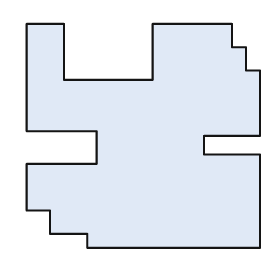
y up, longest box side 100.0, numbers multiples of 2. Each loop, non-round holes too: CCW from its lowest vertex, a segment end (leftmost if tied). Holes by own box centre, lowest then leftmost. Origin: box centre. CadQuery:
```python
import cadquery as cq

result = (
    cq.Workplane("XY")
    .moveTo(-24.0, -48.0)
    .lineTo(50.0, -48.0)
    .lineTo(50.0, -8.0)
    .lineTo(26.0, -8.0)
    .lineTo(26.0, 0.0)
    .lineTo(50.0, 0.0)
    .lineTo(50.0, 28.0)
    .lineTo(44.0, 28.0)
    .lineTo(44.0, 38.0)
    .lineTo(38.0, 38.0)
    .lineTo(38.0, 48.0)
    .lineTo(4.0, 48.0)
    .lineTo(4.0, 24.0)
    .lineTo(-34.0, 24.0)
    .lineTo(-34.0, 48.0)
    .lineTo(-50.0, 48.0)
    .lineTo(-50.0, 2.0)
    .lineTo(-20.0, 2.0)
    .lineTo(-20.0, -12.0)
    .lineTo(-50.0, -12.0)
    .lineTo(-50.0, -32.0)
    .lineTo(-40.0, -32.0)
    .lineTo(-40.0, -42.0)
    .lineTo(-24.0, -42.0)
    .close()
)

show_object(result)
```